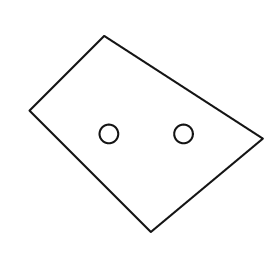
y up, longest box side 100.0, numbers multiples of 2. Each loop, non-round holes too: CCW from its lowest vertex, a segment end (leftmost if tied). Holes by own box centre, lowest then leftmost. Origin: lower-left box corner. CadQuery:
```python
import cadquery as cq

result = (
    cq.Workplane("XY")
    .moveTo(52.0, 0.0)
    .lineTo(100.0, 40.0)
    .lineTo(32.0, 84.0)
    .lineTo(0.0, 52.0)
    .close()
    .moveTo(34.0, 42.0)
    .circle(4.0)
    .moveTo(66.0, 42.0)
    .circle(4.0)
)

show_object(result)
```